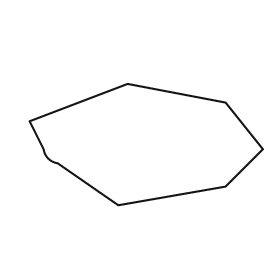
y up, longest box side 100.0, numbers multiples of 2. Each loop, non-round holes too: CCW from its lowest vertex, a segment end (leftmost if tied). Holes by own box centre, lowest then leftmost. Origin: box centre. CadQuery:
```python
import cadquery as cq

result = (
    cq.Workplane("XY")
    .moveTo(-12.0, -26.0)
    .lineTo(34.0, -18.0)
    .lineTo(50.0, -2.0)
    .lineTo(34.0, 18.0)
    .lineTo(-8.0, 26.0)
    .lineTo(-50.0, 10.0)
    .lineTo(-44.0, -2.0)
    .threePointArc((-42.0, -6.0), (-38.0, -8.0))
    .close()
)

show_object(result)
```